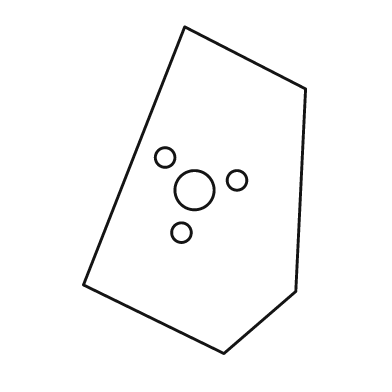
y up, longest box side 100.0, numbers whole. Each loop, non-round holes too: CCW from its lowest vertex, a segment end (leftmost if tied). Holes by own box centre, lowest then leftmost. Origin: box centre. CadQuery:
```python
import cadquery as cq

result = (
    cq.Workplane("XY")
    .moveTo(9.0, -50.0)
    .lineTo(31.0, -31.0)
    .lineTo(34.0, 31.0)
    .lineTo(-3.0, 50.0)
    .lineTo(-34.0, -29.0)
    .close()
    .moveTo(-4.0, -13.0)
    .circle(3.0)
    .moveTo(0.0, 0.0)
    .circle(6.0)
    .moveTo(13.0, 3.0)
    .circle(3.0)
    .moveTo(-9.0, 10.0)
    .circle(3.0)
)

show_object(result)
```